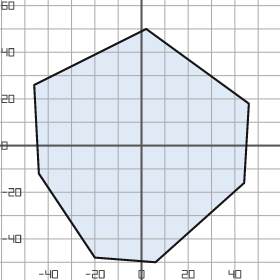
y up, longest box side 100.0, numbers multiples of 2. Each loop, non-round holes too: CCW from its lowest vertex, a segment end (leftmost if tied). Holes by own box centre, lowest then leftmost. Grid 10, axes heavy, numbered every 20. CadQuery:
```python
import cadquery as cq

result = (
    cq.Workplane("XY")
    .moveTo(6.0, -50.0)
    .lineTo(44.0, -16.0)
    .lineTo(46.0, 18.0)
    .lineTo(2.0, 50.0)
    .lineTo(-46.0, 26.0)
    .lineTo(-44.0, -12.0)
    .lineTo(-20.0, -48.0)
    .close()
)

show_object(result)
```